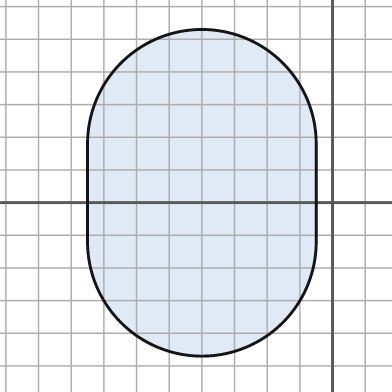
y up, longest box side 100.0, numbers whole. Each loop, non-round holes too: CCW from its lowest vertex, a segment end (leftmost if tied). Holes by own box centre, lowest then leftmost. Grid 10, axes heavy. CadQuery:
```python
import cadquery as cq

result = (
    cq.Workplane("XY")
    .moveTo(-75.0, -12.0)
    .threePointArc((-40.0, -47.0), (-5.0, -12.0))
    .lineTo(-5.0, 18.0)
    .threePointArc((-40.0, 53.0), (-75.0, 18.0))
    .close()
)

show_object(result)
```